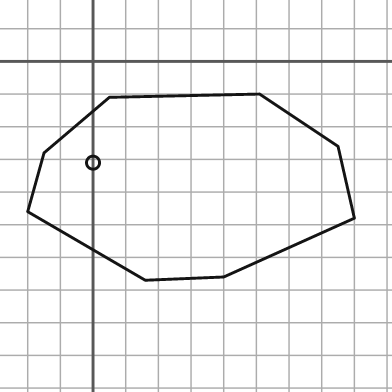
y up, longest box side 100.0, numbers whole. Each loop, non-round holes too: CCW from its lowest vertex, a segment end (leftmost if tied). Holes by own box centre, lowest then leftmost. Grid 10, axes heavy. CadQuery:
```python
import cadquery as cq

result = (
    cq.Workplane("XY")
    .moveTo(16.0, -67.0)
    .lineTo(40.0, -66.0)
    .lineTo(80.0, -48.0)
    .lineTo(75.0, -26.0)
    .lineTo(51.0, -10.0)
    .lineTo(5.0, -11.0)
    .lineTo(-15.0, -28.0)
    .lineTo(-20.0, -46.0)
    .close()
    .moveTo(0.0, -31.0)
    .circle(2.0)
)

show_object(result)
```